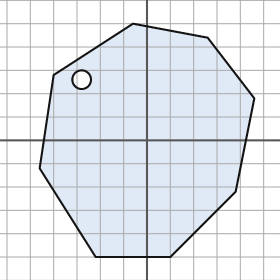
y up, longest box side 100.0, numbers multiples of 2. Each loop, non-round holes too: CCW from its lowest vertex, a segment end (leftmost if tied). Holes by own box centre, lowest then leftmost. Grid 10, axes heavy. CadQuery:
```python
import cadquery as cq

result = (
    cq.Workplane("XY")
    .moveTo(-22.0, -50.0)
    .lineTo(10.0, -50.0)
    .lineTo(38.0, -22.0)
    .lineTo(46.0, 18.0)
    .lineTo(26.0, 44.0)
    .lineTo(-6.0, 50.0)
    .lineTo(-40.0, 28.0)
    .lineTo(-46.0, -12.0)
    .close()
    .moveTo(-28.0, 26.0)
    .circle(4.0)
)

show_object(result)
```